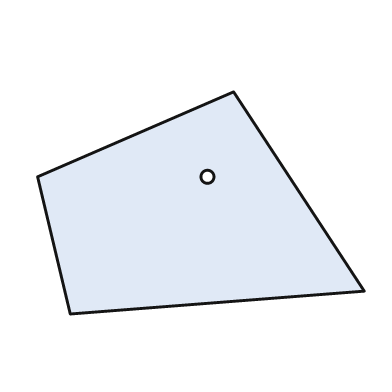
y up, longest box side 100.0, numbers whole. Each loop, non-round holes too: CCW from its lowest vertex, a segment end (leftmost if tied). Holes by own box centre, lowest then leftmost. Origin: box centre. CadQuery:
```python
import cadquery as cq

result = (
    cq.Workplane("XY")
    .moveTo(-40.0, -34.0)
    .lineTo(50.0, -27.0)
    .lineTo(10.0, 34.0)
    .lineTo(-50.0, 8.0)
    .close()
    .moveTo(2.0, 8.0)
    .circle(2.0)
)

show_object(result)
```